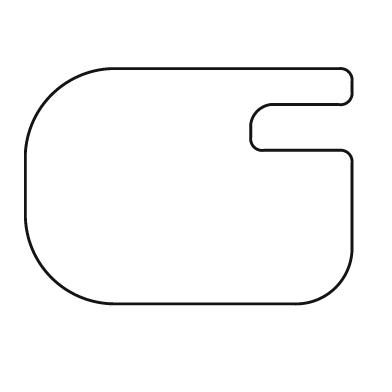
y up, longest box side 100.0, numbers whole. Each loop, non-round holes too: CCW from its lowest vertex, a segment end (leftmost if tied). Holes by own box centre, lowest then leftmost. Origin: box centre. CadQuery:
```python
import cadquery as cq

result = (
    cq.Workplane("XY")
    .moveTo(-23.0, -36.0)
    .lineTo(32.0, -36.0)
    .threePointArc((45.0, -31.0), (50.0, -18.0))
    .lineTo(50.0, 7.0)
    .threePointArc((49.0, 10.0), (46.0, 11.0))
    .lineTo(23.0, 11.0)
    .threePointArc((20.0, 12.0), (19.0, 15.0))
    .lineTo(19.0, 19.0)
    .threePointArc((21.0, 23.0), (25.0, 25.0))
    .lineTo(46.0, 25.0)
    .threePointArc((49.0, 26.0), (50.0, 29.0))
    .lineTo(50.0, 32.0)
    .threePointArc((49.0, 35.0), (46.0, 36.0))
    .lineTo(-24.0, 36.0)
    .threePointArc((-42.0, 28.0), (-50.0, 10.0))
    .lineTo(-50.0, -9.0)
    .threePointArc((-42.0, -28.0), (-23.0, -36.0))
    .close()
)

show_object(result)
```